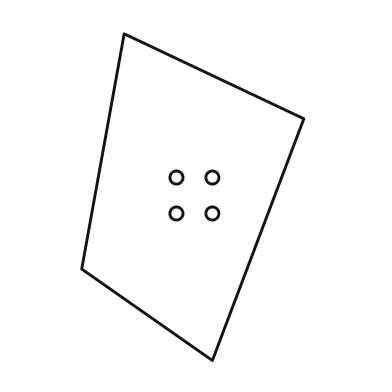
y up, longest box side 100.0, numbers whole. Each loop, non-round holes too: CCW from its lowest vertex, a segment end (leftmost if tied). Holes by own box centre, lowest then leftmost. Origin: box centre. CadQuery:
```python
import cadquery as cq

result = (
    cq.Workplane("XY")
    .moveTo(6.0, -50.0)
    .lineTo(34.0, 24.0)
    .lineTo(-21.0, 50.0)
    .lineTo(-34.0, -22.0)
    .close()
    .moveTo(-5.0, -5.0)
    .circle(2.0)
    .moveTo(6.0, -5.0)
    .circle(2.0)
    .moveTo(-5.0, 6.0)
    .circle(2.0)
    .moveTo(6.0, 6.0)
    .circle(2.0)
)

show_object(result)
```